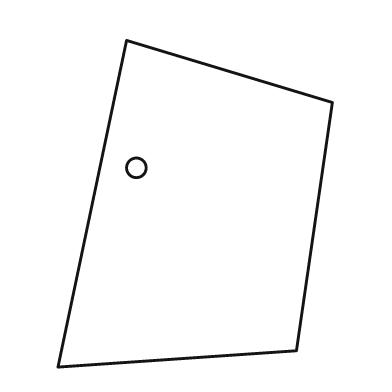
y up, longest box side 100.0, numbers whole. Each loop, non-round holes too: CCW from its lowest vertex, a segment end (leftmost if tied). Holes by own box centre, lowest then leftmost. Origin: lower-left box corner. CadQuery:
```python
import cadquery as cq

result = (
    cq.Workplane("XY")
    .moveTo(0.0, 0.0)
    .lineTo(73.0, 5.0)
    .lineTo(84.0, 81.0)
    .lineTo(21.0, 100.0)
    .close()
    .moveTo(24.0, 61.0)
    .circle(3.0)
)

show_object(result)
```